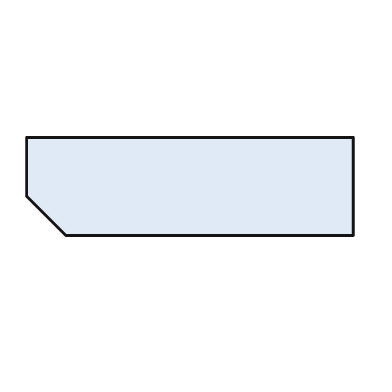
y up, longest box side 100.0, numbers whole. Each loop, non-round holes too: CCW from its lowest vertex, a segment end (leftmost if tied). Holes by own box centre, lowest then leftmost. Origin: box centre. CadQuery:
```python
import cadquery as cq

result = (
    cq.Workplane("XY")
    .moveTo(-38.0, -15.0)
    .lineTo(50.0, -15.0)
    .lineTo(50.0, 15.0)
    .lineTo(-50.0, 15.0)
    .lineTo(-50.0, -3.0)
    .close()
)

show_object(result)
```